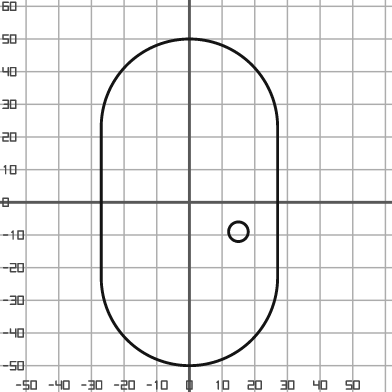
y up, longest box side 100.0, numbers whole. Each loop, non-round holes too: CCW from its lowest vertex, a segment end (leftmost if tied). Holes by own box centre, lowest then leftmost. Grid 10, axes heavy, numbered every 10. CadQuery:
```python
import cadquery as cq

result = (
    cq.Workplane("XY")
    .moveTo(-27.0, -23.0)
    .threePointArc((0.0, -50.0), (27.0, -23.0))
    .lineTo(27.0, 23.0)
    .threePointArc((0.0, 50.0), (-27.0, 23.0))
    .close()
    .moveTo(15.0, -9.0)
    .circle(3.0)
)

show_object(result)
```